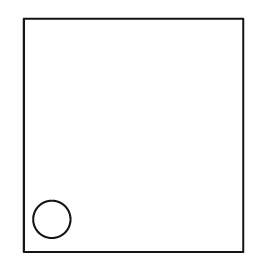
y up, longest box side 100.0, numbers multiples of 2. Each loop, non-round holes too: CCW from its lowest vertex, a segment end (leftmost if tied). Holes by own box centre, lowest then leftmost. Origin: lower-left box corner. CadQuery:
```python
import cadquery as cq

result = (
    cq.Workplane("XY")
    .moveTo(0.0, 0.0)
    .lineTo(94.0, 0.0)
    .lineTo(94.0, 100.0)
    .lineTo(0.0, 100.0)
    .close()
    .moveTo(12.0, 14.0)
    .circle(8.0)
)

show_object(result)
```